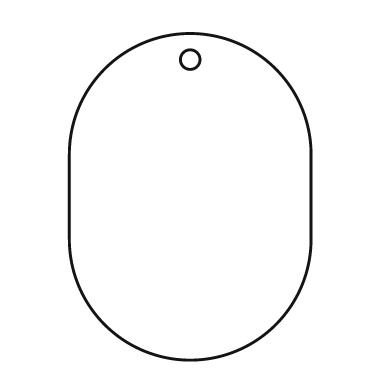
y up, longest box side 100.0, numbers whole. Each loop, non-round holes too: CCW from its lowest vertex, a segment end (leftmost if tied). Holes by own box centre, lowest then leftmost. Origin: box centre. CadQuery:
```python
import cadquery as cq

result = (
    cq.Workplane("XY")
    .moveTo(-37.0, -13.0)
    .threePointArc((0.0, -50.0), (37.0, -13.0))
    .lineTo(37.0, 13.0)
    .threePointArc((0.0, 50.0), (-37.0, 13.0))
    .close()
    .moveTo(0.0, 42.0)
    .circle(3.0)
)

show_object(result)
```